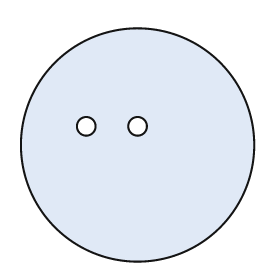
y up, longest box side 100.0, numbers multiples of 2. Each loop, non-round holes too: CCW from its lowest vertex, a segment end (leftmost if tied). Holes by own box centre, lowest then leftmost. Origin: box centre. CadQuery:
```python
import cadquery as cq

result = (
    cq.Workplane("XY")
    .moveTo(0.0, 0.0)
    .circle(50.0)
    .moveTo(-22.0, 8.0)
    .circle(4.0)
    .moveTo(0.0, 8.0)
    .circle(4.0)
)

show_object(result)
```